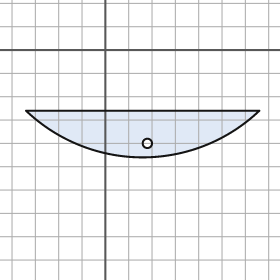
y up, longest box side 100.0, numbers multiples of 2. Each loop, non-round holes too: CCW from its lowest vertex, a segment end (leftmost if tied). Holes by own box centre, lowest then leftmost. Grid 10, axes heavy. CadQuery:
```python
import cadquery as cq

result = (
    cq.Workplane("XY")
    .moveTo(-34.0, -26.0)
    .threePointArc((16.0, -46.0), (66.0, -26.0))
    .close()
    .moveTo(18.0, -40.0)
    .circle(2.0)
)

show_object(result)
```